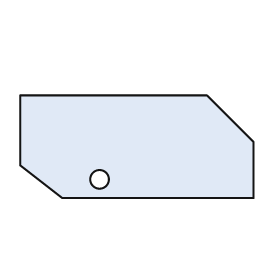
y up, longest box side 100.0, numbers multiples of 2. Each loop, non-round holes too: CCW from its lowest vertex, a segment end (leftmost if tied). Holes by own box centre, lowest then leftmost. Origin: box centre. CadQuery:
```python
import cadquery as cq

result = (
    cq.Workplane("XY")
    .moveTo(-32.0, -22.0)
    .lineTo(50.0, -22.0)
    .lineTo(50.0, 2.0)
    .lineTo(30.0, 22.0)
    .lineTo(-50.0, 22.0)
    .lineTo(-50.0, -8.0)
    .close()
    .moveTo(-16.0, -14.0)
    .circle(4.0)
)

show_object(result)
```